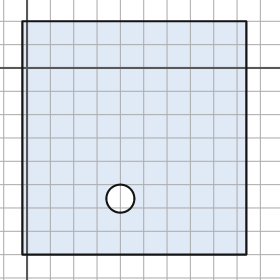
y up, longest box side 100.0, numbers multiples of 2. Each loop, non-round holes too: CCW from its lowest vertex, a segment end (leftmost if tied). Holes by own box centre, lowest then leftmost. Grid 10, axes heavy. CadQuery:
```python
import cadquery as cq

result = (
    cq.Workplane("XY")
    .moveTo(-2.0, -80.0)
    .lineTo(94.0, -80.0)
    .lineTo(94.0, 20.0)
    .lineTo(-2.0, 20.0)
    .close()
    .moveTo(40.0, -56.0)
    .circle(6.0)
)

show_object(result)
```